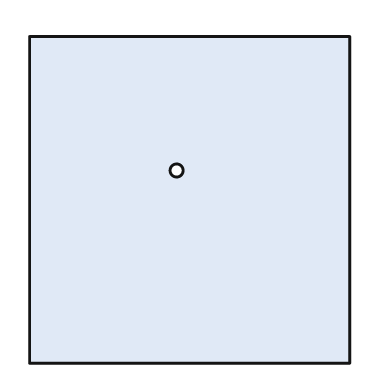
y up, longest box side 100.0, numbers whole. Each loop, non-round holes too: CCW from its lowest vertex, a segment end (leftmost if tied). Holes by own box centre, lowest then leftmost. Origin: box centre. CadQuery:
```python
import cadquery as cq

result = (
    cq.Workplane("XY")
    .moveTo(-49.0, -50.0)
    .lineTo(49.0, -50.0)
    .lineTo(49.0, 50.0)
    .lineTo(-49.0, 50.0)
    .close()
    .moveTo(-4.0, 9.0)
    .circle(2.0)
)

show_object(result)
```